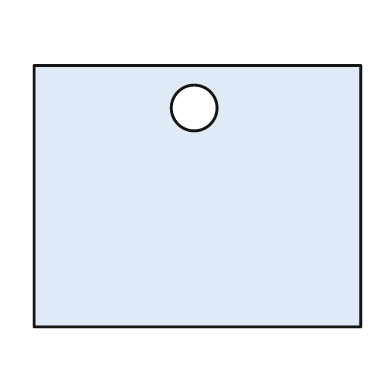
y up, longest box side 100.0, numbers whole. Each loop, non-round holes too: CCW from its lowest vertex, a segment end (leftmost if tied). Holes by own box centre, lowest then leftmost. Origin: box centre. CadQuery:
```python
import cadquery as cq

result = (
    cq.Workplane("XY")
    .moveTo(-50.0, -40.0)
    .lineTo(50.0, -40.0)
    .lineTo(50.0, 40.0)
    .lineTo(-50.0, 40.0)
    .close()
    .moveTo(-1.0, 27.0)
    .circle(7.0)
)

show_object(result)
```